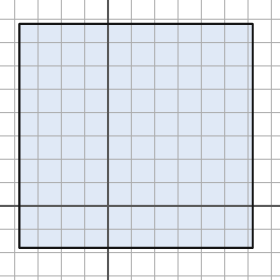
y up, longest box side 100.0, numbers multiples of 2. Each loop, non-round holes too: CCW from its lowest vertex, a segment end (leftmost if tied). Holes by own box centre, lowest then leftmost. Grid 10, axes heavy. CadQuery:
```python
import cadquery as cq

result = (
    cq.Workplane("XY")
    .moveTo(-38.0, -18.0)
    .lineTo(62.0, -18.0)
    .lineTo(62.0, 78.0)
    .lineTo(-38.0, 78.0)
    .close()
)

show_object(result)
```